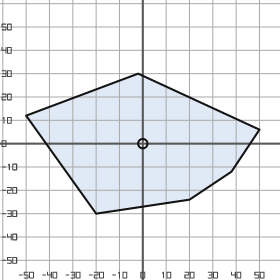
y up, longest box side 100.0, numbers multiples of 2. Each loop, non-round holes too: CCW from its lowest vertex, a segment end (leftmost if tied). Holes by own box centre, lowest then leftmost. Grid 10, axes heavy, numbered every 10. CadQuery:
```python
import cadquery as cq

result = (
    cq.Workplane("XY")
    .moveTo(-20.0, -30.0)
    .lineTo(20.0, -24.0)
    .lineTo(38.0, -12.0)
    .lineTo(50.0, 6.0)
    .lineTo(-2.0, 30.0)
    .lineTo(-50.0, 12.0)
    .close()
    .moveTo(0.0, 0.0)
    .circle(2.0)
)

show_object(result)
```